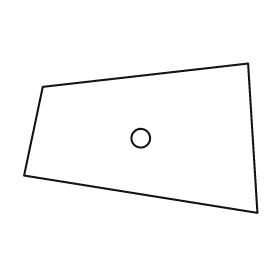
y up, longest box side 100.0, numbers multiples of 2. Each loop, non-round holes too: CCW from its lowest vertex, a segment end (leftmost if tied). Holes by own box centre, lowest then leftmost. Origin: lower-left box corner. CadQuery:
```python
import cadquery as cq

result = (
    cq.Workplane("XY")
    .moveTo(100.0, 0.0)
    .lineTo(96.0, 64.0)
    .lineTo(8.0, 54.0)
    .lineTo(0.0, 16.0)
    .close()
    .moveTo(50.0, 32.0)
    .circle(4.0)
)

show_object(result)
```